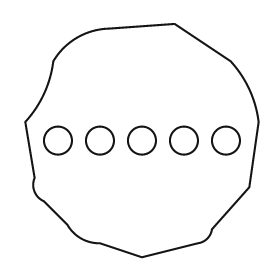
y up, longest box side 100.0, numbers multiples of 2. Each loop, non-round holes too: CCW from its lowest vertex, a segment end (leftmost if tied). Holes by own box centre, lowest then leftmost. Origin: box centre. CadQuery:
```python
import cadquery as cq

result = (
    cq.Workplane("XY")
    .moveTo(0.0, -50.0)
    .lineTo(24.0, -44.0)
    .threePointArc((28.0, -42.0), (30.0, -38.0))
    .lineTo(46.0, -20.0)
    .lineTo(50.0, 8.0)
    .threePointArc((46.0, 22.0), (38.0, 34.0))
    .lineTo(14.0, 50.0)
    .lineTo(-14.0, 48.0)
    .threePointArc((-28.0, 44.0), (-38.0, 34.0))
    .threePointArc((-42.0, 20.0), (-50.0, 8.0))
    .lineTo(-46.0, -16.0)
    .threePointArc((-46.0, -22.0), (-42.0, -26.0))
    .lineTo(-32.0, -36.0)
    .threePointArc((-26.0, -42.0), (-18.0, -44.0))
    .close()
    .moveTo(-36.0, 0.0)
    .circle(6.0)
    .moveTo(-18.0, 0.0)
    .circle(6.0)
    .moveTo(0.0, 0.0)
    .circle(6.0)
    .moveTo(18.0, 0.0)
    .circle(6.0)
    .moveTo(36.0, 0.0)
    .circle(6.0)
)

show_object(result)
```